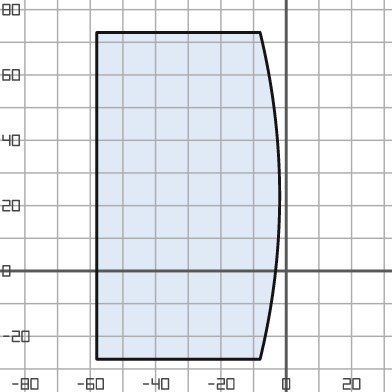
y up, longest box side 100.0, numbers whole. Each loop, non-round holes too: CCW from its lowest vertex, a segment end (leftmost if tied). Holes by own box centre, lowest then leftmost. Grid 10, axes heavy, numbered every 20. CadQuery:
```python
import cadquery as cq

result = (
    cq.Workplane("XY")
    .moveTo(-58.0, -27.0)
    .lineTo(-8.0, -27.0)
    .threePointArc((-2.0, 23.0), (-8.0, 73.0))
    .lineTo(-58.0, 73.0)
    .close()
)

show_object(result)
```